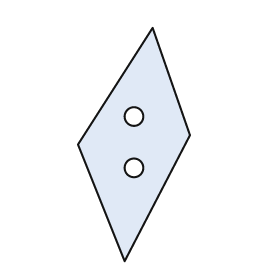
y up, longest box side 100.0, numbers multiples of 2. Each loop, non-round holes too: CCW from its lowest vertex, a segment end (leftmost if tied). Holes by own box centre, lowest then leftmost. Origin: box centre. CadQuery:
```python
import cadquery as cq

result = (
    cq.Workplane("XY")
    .moveTo(-4.0, -50.0)
    .lineTo(24.0, 4.0)
    .lineTo(8.0, 50.0)
    .lineTo(-24.0, 0.0)
    .close()
    .moveTo(0.0, -10.0)
    .circle(4.0)
    .moveTo(0.0, 12.0)
    .circle(4.0)
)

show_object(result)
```